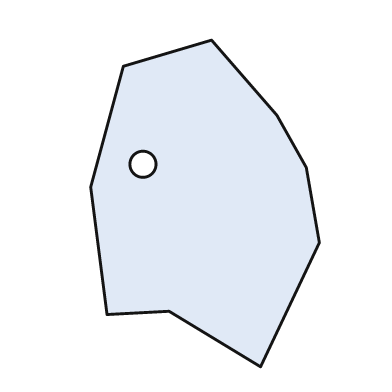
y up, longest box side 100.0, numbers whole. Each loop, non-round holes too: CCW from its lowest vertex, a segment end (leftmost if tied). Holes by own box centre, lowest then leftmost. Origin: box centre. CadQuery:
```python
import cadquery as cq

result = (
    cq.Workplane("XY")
    .moveTo(17.0, -50.0)
    .lineTo(35.0, -12.0)
    .lineTo(31.0, 11.0)
    .lineTo(22.0, 27.0)
    .lineTo(2.0, 50.0)
    .lineTo(-25.0, 42.0)
    .lineTo(-35.0, 5.0)
    .lineTo(-30.0, -34.0)
    .lineTo(-11.0, -33.0)
    .close()
    .moveTo(-19.0, 12.0)
    .circle(4.0)
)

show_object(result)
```